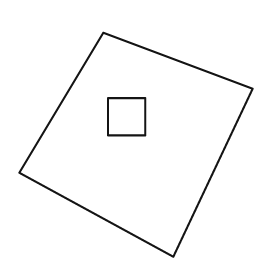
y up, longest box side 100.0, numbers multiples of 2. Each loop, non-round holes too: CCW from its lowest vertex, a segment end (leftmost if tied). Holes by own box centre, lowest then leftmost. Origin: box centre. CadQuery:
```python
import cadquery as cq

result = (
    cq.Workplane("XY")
    .moveTo(16.0, -48.0)
    .lineTo(50.0, 24.0)
    .lineTo(-14.0, 48.0)
    .lineTo(-50.0, -12.0)
    .close()
    .moveTo(-12.0, 4.0)
    .lineTo(4.0, 4.0)
    .lineTo(4.0, 20.0)
    .lineTo(-12.0, 20.0)
    .close()
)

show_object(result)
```